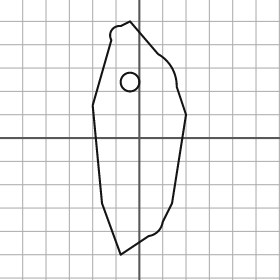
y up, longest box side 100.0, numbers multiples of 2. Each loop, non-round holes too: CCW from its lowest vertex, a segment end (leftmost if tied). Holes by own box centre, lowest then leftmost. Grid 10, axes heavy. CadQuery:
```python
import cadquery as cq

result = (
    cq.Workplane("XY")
    .moveTo(-8.0, -50.0)
    .lineTo(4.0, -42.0)
    .threePointArc((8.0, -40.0), (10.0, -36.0))
    .lineTo(14.0, -28.0)
    .lineTo(20.0, 10.0)
    .lineTo(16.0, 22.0)
    .threePointArc((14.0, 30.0), (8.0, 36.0))
    .lineTo(-4.0, 50.0)
    .lineTo(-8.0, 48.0)
    .threePointArc((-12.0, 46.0), (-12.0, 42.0))
    .lineTo(-20.0, 14.0)
    .lineTo(-16.0, -28.0)
    .close()
    .moveTo(-4.0, 24.0)
    .circle(4.0)
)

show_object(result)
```